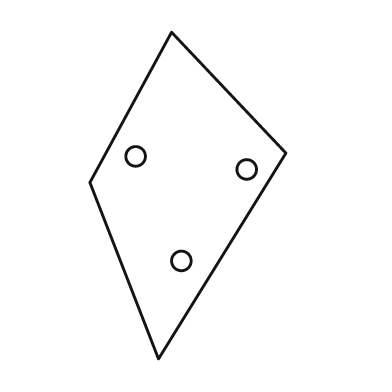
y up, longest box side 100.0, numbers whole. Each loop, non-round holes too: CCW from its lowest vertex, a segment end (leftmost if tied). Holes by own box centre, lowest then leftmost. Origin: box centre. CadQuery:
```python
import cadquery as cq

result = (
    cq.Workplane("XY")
    .moveTo(-9.0, -50.0)
    .lineTo(30.0, 13.0)
    .lineTo(-5.0, 50.0)
    .lineTo(-30.0, 4.0)
    .close()
    .moveTo(-2.0, -20.0)
    .circle(3.0)
    .moveTo(18.0, 8.0)
    .circle(3.0)
    .moveTo(-16.0, 12.0)
    .circle(3.0)
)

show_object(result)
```